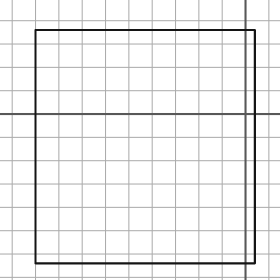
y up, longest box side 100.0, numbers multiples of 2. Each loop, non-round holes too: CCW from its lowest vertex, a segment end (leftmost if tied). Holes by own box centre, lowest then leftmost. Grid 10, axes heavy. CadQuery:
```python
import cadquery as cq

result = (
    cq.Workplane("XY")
    .moveTo(-90.0, -64.0)
    .lineTo(4.0, -64.0)
    .lineTo(4.0, 36.0)
    .lineTo(-90.0, 36.0)
    .close()
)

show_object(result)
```